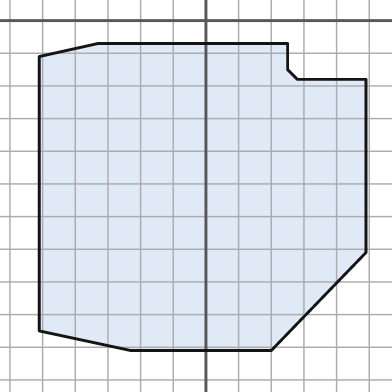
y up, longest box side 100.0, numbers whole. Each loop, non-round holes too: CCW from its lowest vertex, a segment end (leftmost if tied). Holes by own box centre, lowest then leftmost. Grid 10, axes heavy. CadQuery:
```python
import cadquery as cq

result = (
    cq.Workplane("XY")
    .moveTo(-23.0, -101.0)
    .lineTo(20.0, -101.0)
    .lineTo(49.0, -71.0)
    .lineTo(49.0, -18.0)
    .lineTo(28.0, -18.0)
    .lineTo(25.0, -15.0)
    .lineTo(25.0, -7.0)
    .lineTo(-33.0, -7.0)
    .lineTo(-51.0, -11.0)
    .lineTo(-51.0, -95.0)
    .close()
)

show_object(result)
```